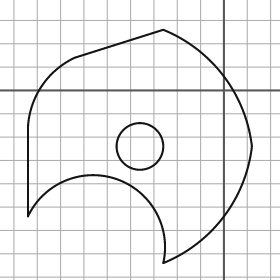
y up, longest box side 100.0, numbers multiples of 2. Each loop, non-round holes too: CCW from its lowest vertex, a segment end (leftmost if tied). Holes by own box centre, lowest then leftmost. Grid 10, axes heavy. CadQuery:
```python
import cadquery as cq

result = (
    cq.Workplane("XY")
    .moveTo(-26.0, -74.0)
    .threePointArc((0.0, -54.0), (12.0, -24.0))
    .threePointArc((0.0, 6.0), (-26.0, 26.0))
    .lineTo(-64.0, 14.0)
    .threePointArc((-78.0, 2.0), (-84.0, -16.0))
    .lineTo(-84.0, -54.0)
    .threePointArc((-46.0, -38.0), (-26.0, -74.0))
    .close()
    .moveTo(-36.0, -24.0)
    .circle(10.0)
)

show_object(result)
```